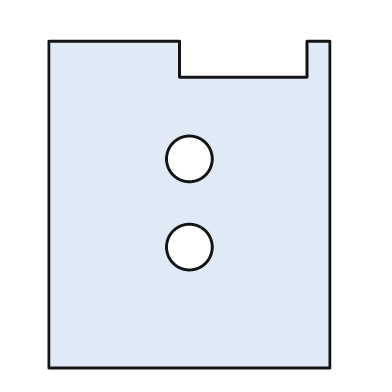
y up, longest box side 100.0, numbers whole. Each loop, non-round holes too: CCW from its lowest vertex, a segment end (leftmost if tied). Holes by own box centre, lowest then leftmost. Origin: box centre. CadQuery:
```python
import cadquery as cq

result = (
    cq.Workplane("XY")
    .moveTo(-43.0, -50.0)
    .lineTo(43.0, -50.0)
    .lineTo(43.0, 50.0)
    .lineTo(36.0, 50.0)
    .lineTo(36.0, 39.0)
    .lineTo(-3.0, 39.0)
    .lineTo(-3.0, 50.0)
    .lineTo(-43.0, 50.0)
    .close()
    .moveTo(0.0, -13.0)
    .circle(7.0)
    .moveTo(0.0, 14.0)
    .circle(7.0)
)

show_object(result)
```